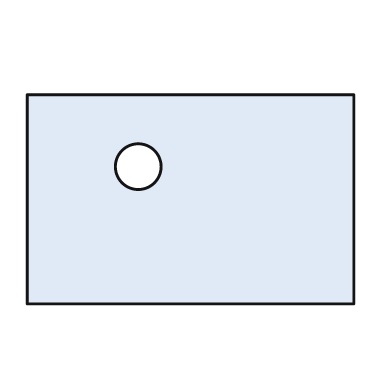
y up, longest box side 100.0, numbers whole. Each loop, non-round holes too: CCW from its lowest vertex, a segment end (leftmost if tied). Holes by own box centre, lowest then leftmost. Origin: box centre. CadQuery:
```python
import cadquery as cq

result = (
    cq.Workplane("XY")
    .moveTo(-50.0, -32.0)
    .lineTo(50.0, -32.0)
    .lineTo(50.0, 32.0)
    .lineTo(-50.0, 32.0)
    .close()
    .moveTo(-16.0, 10.0)
    .circle(7.0)
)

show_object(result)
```